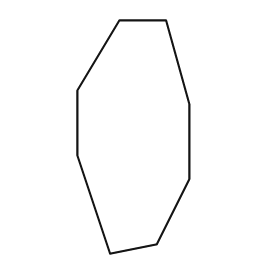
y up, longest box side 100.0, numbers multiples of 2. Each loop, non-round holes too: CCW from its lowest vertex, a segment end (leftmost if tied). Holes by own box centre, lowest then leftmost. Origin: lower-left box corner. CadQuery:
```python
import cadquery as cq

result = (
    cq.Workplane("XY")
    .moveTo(14.0, 0.0)
    .lineTo(34.0, 4.0)
    .lineTo(48.0, 32.0)
    .lineTo(48.0, 64.0)
    .lineTo(38.0, 100.0)
    .lineTo(18.0, 100.0)
    .lineTo(0.0, 70.0)
    .lineTo(0.0, 42.0)
    .close()
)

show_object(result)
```